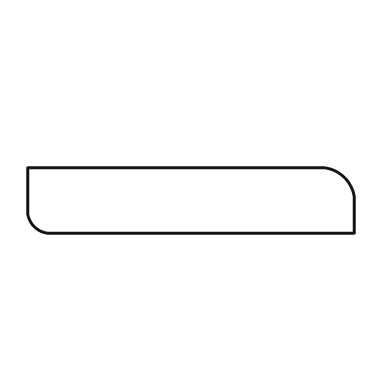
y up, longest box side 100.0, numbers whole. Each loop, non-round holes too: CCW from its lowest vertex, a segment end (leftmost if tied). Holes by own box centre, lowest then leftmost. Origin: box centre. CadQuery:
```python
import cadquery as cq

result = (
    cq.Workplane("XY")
    .moveTo(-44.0, -10.0)
    .lineTo(50.0, -10.0)
    .lineTo(50.0, 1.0)
    .threePointArc((47.0, 7.0), (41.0, 10.0))
    .lineTo(-50.0, 10.0)
    .lineTo(-50.0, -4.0)
    .threePointArc((-48.0, -8.0), (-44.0, -10.0))
    .close()
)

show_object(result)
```